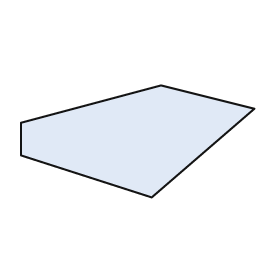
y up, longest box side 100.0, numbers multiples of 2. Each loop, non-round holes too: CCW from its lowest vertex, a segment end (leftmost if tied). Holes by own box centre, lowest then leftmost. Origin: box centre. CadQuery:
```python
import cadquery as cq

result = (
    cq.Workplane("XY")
    .moveTo(6.0, -24.0)
    .lineTo(50.0, 14.0)
    .lineTo(10.0, 24.0)
    .lineTo(-50.0, 8.0)
    .lineTo(-50.0, -6.0)
    .close()
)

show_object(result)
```